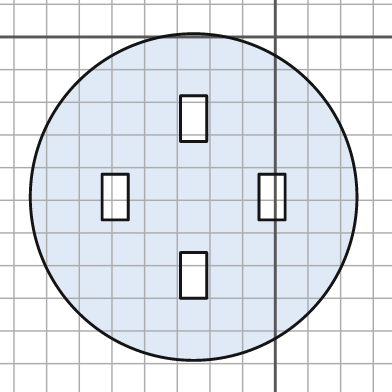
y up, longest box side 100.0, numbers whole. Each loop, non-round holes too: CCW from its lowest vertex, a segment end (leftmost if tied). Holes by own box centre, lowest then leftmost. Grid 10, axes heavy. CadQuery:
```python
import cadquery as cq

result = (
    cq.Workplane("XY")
    .moveTo(-25.0, -49.0)
    .circle(50.0)
    .moveTo(-29.0, -80.0)
    .lineTo(-21.0, -80.0)
    .lineTo(-21.0, -66.0)
    .lineTo(-29.0, -66.0)
    .close()
    .moveTo(-53.0, -56.0)
    .lineTo(-45.0, -56.0)
    .lineTo(-45.0, -42.0)
    .lineTo(-53.0, -42.0)
    .close()
    .moveTo(-5.0, -56.0)
    .lineTo(3.0, -56.0)
    .lineTo(3.0, -42.0)
    .lineTo(-5.0, -42.0)
    .close()
    .moveTo(-29.0, -32.0)
    .lineTo(-21.0, -32.0)
    .lineTo(-21.0, -18.0)
    .lineTo(-29.0, -18.0)
    .close()
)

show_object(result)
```